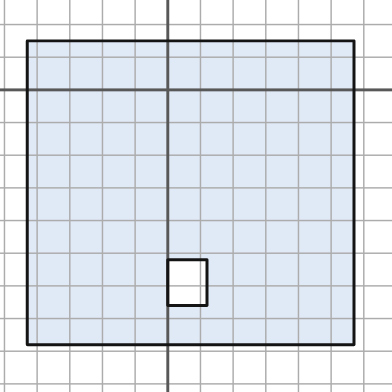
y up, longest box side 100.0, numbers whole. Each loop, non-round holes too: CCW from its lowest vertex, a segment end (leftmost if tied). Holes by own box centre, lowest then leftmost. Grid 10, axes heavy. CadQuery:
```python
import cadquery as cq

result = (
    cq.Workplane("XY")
    .moveTo(-43.0, -78.0)
    .lineTo(57.0, -78.0)
    .lineTo(57.0, 15.0)
    .lineTo(-43.0, 15.0)
    .close()
    .moveTo(0.0, -66.0)
    .lineTo(12.0, -66.0)
    .lineTo(12.0, -52.0)
    .lineTo(0.0, -52.0)
    .close()
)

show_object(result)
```